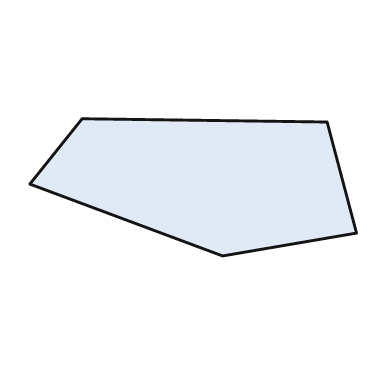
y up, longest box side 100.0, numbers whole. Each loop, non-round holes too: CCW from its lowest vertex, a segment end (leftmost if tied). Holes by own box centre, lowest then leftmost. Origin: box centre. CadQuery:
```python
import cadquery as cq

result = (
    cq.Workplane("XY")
    .moveTo(9.0, -21.0)
    .lineTo(50.0, -14.0)
    .lineTo(41.0, 20.0)
    .lineTo(-34.0, 21.0)
    .lineTo(-50.0, 1.0)
    .close()
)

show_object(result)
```